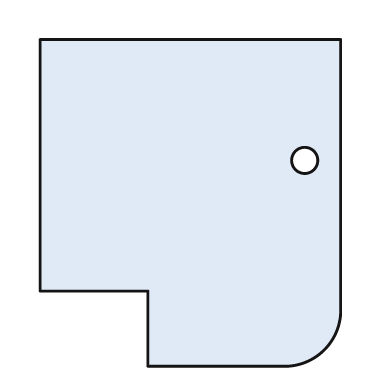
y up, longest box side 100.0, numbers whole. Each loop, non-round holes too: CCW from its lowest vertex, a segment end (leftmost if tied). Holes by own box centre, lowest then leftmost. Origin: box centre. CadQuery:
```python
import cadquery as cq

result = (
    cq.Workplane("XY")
    .moveTo(-13.0, -50.0)
    .lineTo(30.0, -50.0)
    .threePointArc((41.0, -45.0), (46.0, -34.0))
    .lineTo(46.0, 50.0)
    .lineTo(-46.0, 50.0)
    .lineTo(-46.0, -27.0)
    .lineTo(-13.0, -27.0)
    .close()
    .moveTo(35.0, 13.0)
    .circle(4.0)
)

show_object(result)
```